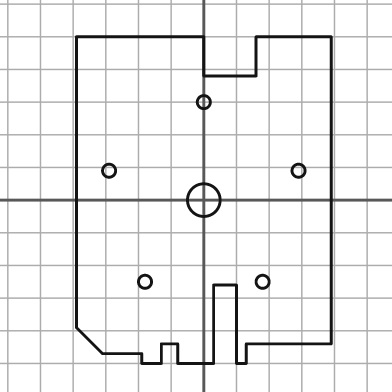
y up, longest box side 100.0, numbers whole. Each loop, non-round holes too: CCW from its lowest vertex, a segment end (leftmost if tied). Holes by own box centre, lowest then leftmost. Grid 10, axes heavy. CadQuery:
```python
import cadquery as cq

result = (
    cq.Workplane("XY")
    .moveTo(-19.0, -50.0)
    .lineTo(-13.0, -50.0)
    .lineTo(-13.0, -44.0)
    .lineTo(-8.0, -44.0)
    .lineTo(-8.0, -50.0)
    .lineTo(3.0, -50.0)
    .lineTo(3.0, -26.0)
    .lineTo(10.0, -26.0)
    .lineTo(10.0, -50.0)
    .lineTo(13.0, -50.0)
    .lineTo(13.0, -44.0)
    .lineTo(39.0, -44.0)
    .lineTo(39.0, 50.0)
    .lineTo(16.0, 50.0)
    .lineTo(16.0, 38.0)
    .lineTo(0.0, 38.0)
    .lineTo(0.0, 50.0)
    .lineTo(-39.0, 50.0)
    .lineTo(-39.0, -39.0)
    .lineTo(-31.0, -47.0)
    .lineTo(-19.0, -47.0)
    .close()
    .moveTo(-18.0, -25.0)
    .circle(2.0)
    .moveTo(18.0, -25.0)
    .circle(2.0)
    .moveTo(0.0, 0.0)
    .circle(5.0)
    .moveTo(-29.0, 9.0)
    .circle(2.0)
    .moveTo(29.0, 9.0)
    .circle(2.0)
    .moveTo(0.0, 30.0)
    .circle(2.0)
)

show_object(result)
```